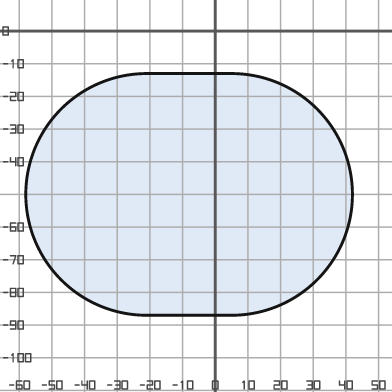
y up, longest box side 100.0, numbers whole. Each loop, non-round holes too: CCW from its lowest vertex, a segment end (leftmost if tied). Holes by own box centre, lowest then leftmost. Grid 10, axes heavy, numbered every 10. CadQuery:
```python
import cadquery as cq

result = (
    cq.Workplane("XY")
    .moveTo(-21.0, -87.0)
    .lineTo(5.0, -87.0)
    .threePointArc((42.0, -50.0), (5.0, -13.0))
    .lineTo(-21.0, -13.0)
    .threePointArc((-58.0, -50.0), (-21.0, -87.0))
    .close()
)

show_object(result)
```